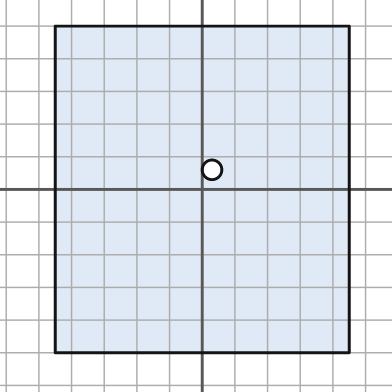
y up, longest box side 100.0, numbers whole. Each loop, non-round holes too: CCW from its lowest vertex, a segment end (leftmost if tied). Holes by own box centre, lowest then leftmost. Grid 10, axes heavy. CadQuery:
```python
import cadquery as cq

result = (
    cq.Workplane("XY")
    .moveTo(-45.0, -50.0)
    .lineTo(45.0, -50.0)
    .lineTo(45.0, 50.0)
    .lineTo(-45.0, 50.0)
    .close()
    .moveTo(3.0, 6.0)
    .circle(3.0)
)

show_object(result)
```